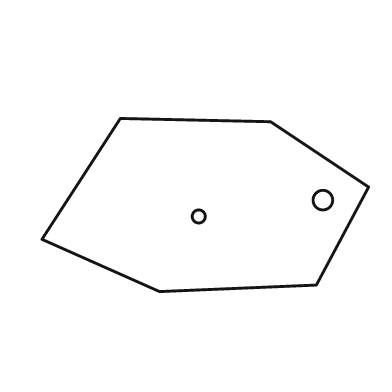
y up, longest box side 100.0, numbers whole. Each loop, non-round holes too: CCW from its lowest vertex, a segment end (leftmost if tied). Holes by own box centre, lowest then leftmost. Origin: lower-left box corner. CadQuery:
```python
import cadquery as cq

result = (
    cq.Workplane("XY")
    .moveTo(36.0, 0.0)
    .lineTo(84.0, 2.0)
    .lineTo(100.0, 32.0)
    .lineTo(70.0, 52.0)
    .lineTo(24.0, 53.0)
    .lineTo(0.0, 16.0)
    .close()
    .moveTo(48.0, 23.0)
    .circle(2.0)
    .moveTo(86.0, 28.0)
    .circle(3.0)
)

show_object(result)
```